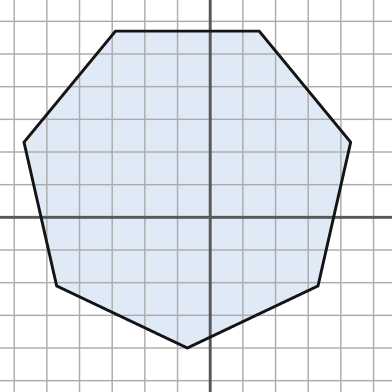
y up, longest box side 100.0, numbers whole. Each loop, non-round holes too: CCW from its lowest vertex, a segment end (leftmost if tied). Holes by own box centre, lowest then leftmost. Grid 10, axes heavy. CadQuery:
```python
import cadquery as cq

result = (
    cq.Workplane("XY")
    .moveTo(-7.0, -40.0)
    .lineTo(33.0, -21.0)
    .lineTo(43.0, 23.0)
    .lineTo(15.0, 57.0)
    .lineTo(-29.0, 57.0)
    .lineTo(-57.0, 23.0)
    .lineTo(-47.0, -21.0)
    .close()
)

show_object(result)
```